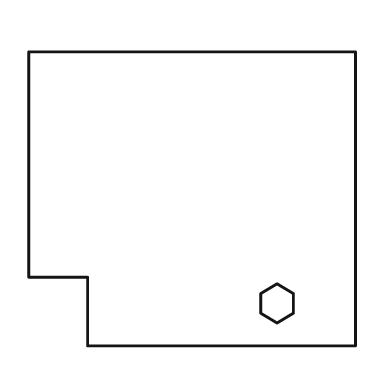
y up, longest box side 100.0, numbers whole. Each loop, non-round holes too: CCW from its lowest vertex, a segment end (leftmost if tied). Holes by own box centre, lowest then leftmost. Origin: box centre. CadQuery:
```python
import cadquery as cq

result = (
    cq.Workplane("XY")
    .moveTo(-32.0, -45.0)
    .lineTo(50.0, -45.0)
    .lineTo(50.0, 45.0)
    .lineTo(-50.0, 45.0)
    .lineTo(-50.0, -24.0)
    .lineTo(-32.0, -24.0)
    .close()
    .moveTo(26.0, -38.0)
    .lineTo(31.0, -35.0)
    .lineTo(31.0, -29.0)
    .lineTo(26.0, -26.0)
    .lineTo(21.0, -29.0)
    .lineTo(21.0, -35.0)
    .close()
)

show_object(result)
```